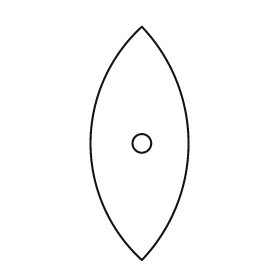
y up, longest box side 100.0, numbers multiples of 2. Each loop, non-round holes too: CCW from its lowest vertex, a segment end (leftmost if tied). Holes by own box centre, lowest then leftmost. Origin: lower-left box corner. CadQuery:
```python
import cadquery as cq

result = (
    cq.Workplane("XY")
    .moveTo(22.0, 0.0)
    .threePointArc((42.0, 50.0), (22.0, 100.0))
    .threePointArc((0.0, 50.0), (22.0, 0.0))
    .close()
    .moveTo(22.0, 50.0)
    .circle(4.0)
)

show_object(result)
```